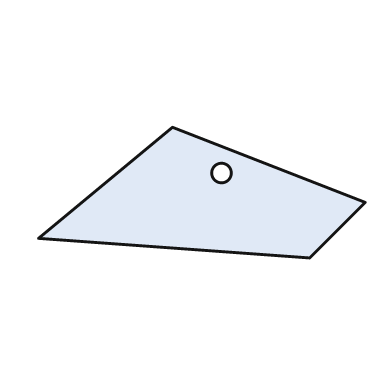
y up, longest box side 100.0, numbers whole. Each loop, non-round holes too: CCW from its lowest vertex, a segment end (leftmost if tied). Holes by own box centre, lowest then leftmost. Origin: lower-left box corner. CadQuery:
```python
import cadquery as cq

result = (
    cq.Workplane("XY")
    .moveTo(83.0, 0.0)
    .lineTo(100.0, 17.0)
    .lineTo(41.0, 40.0)
    .lineTo(0.0, 6.0)
    .close()
    .moveTo(56.0, 26.0)
    .circle(3.0)
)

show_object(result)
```